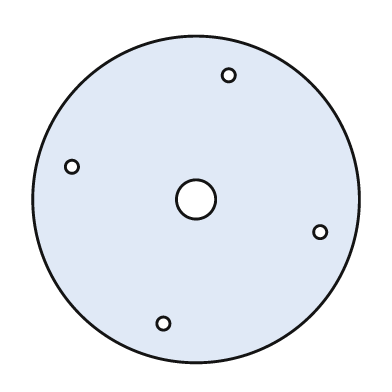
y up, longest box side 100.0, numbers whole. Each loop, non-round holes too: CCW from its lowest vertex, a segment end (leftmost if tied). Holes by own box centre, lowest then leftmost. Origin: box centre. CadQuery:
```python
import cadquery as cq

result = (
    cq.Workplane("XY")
    .moveTo(0.0, 0.0)
    .circle(50.0)
    .moveTo(-10.0, -38.0)
    .circle(2.0)
    .moveTo(38.0, -10.0)
    .circle(2.0)
    .moveTo(0.0, 0.0)
    .circle(6.0)
    .moveTo(-38.0, 10.0)
    .circle(2.0)
    .moveTo(10.0, 38.0)
    .circle(2.0)
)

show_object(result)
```